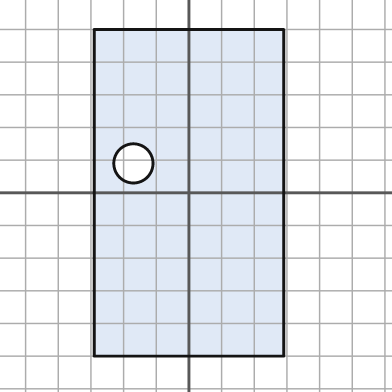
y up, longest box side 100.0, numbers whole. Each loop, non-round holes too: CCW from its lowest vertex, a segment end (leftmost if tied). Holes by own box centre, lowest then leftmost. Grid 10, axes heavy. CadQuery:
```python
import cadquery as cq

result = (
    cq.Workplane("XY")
    .moveTo(-29.0, -50.0)
    .lineTo(29.0, -50.0)
    .lineTo(29.0, 50.0)
    .lineTo(-29.0, 50.0)
    .close()
    .moveTo(-17.0, 9.0)
    .circle(6.0)
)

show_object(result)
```